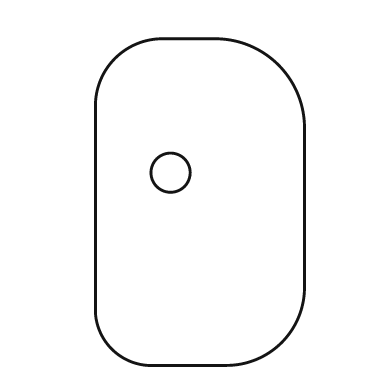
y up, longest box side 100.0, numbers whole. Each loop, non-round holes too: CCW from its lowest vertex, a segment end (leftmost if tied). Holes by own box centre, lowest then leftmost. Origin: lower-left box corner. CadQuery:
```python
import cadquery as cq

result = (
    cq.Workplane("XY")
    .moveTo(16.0, 0.0)
    .lineTo(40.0, 0.0)
    .threePointArc((57.0, 7.0), (64.0, 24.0))
    .lineTo(64.0, 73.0)
    .threePointArc((56.0, 92.0), (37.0, 100.0))
    .lineTo(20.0, 100.0)
    .threePointArc((6.0, 94.0), (0.0, 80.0))
    .lineTo(0.0, 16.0)
    .threePointArc((5.0, 5.0), (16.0, 0.0))
    .close()
    .moveTo(23.0, 59.0)
    .circle(6.0)
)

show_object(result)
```